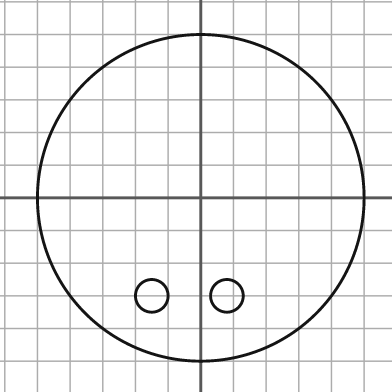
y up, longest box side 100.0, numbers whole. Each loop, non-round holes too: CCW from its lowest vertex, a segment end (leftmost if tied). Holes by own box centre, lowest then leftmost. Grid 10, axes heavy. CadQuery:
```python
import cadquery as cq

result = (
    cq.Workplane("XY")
    .moveTo(0.0, 0.0)
    .circle(50.0)
    .moveTo(-15.0, -30.0)
    .circle(5.0)
    .moveTo(8.0, -30.0)
    .circle(5.0)
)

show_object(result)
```